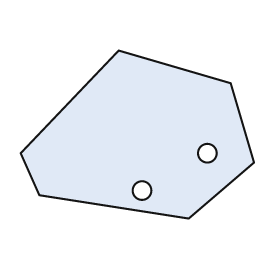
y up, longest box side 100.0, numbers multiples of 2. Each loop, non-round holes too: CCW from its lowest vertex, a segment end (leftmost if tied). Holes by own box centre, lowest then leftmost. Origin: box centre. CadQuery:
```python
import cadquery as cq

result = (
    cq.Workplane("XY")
    .moveTo(22.0, -36.0)
    .lineTo(50.0, -12.0)
    .lineTo(40.0, 22.0)
    .lineTo(-8.0, 36.0)
    .lineTo(-50.0, -8.0)
    .lineTo(-42.0, -26.0)
    .close()
    .moveTo(2.0, -24.0)
    .circle(4.0)
    .moveTo(30.0, -8.0)
    .circle(4.0)
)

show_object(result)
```